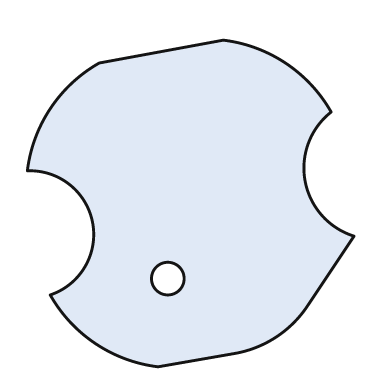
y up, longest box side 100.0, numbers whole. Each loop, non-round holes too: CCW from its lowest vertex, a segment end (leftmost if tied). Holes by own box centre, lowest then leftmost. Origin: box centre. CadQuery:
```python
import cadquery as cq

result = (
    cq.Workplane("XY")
    .moveTo(-10.0, -50.0)
    .lineTo(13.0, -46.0)
    .threePointArc((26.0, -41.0), (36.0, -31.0))
    .lineTo(50.0, -10.0)
    .threePointArc((35.0, 7.0), (43.0, 28.0))
    .threePointArc((29.0, 43.0), (10.0, 50.0))
    .lineTo(-28.0, 43.0)
    .threePointArc((-43.0, 29.0), (-50.0, 10.0))
    .threePointArc((-30.0, -6.0), (-43.0, -28.0))
    .threePointArc((-29.0, -43.0), (-10.0, -50.0))
    .close()
    .moveTo(-7.0, -23.0)
    .circle(5.0)
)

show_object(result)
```